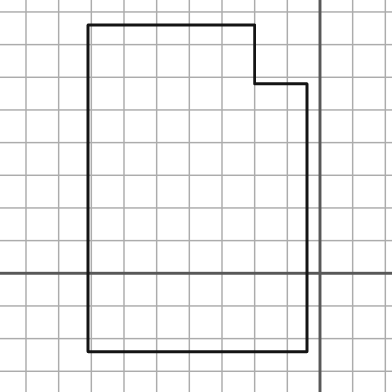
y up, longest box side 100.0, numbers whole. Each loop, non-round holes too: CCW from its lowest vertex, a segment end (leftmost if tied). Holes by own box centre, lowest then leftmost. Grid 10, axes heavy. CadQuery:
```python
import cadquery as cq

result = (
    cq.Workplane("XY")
    .moveTo(-71.0, -24.0)
    .lineTo(-4.0, -24.0)
    .lineTo(-4.0, 58.0)
    .lineTo(-20.0, 58.0)
    .lineTo(-20.0, 76.0)
    .lineTo(-71.0, 76.0)
    .close()
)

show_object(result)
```